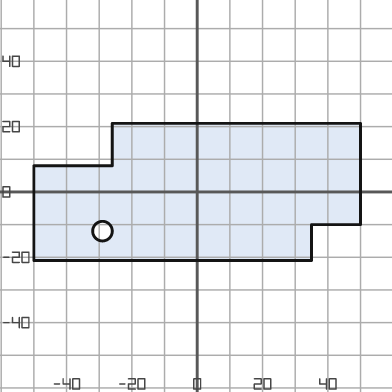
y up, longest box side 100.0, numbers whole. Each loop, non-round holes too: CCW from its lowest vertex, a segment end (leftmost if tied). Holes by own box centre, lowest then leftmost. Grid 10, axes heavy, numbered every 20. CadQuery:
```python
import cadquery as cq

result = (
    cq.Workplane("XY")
    .moveTo(-50.0, -21.0)
    .lineTo(35.0, -21.0)
    .lineTo(35.0, -10.0)
    .lineTo(50.0, -10.0)
    .lineTo(50.0, 21.0)
    .lineTo(-26.0, 21.0)
    .lineTo(-26.0, 8.0)
    .lineTo(-50.0, 8.0)
    .close()
    .moveTo(-29.0, -12.0)
    .circle(3.0)
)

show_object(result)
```